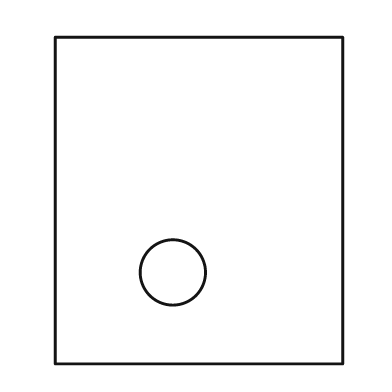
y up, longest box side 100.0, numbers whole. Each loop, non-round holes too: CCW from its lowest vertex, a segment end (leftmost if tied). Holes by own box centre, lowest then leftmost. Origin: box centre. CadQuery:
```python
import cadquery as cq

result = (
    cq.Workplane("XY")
    .moveTo(-44.0, -50.0)
    .lineTo(44.0, -50.0)
    .lineTo(44.0, 50.0)
    .lineTo(-44.0, 50.0)
    .close()
    .moveTo(-8.0, -22.0)
    .circle(10.0)
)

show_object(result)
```